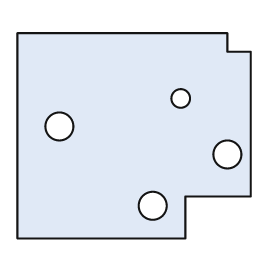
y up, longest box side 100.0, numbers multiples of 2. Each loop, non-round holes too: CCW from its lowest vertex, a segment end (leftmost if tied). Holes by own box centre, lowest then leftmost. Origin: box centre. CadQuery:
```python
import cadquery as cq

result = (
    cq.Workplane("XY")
    .moveTo(-50.0, -44.0)
    .lineTo(22.0, -44.0)
    .lineTo(22.0, -26.0)
    .lineTo(50.0, -26.0)
    .lineTo(50.0, 36.0)
    .lineTo(40.0, 36.0)
    .lineTo(40.0, 44.0)
    .lineTo(-50.0, 44.0)
    .close()
    .moveTo(8.0, -30.0)
    .circle(6.0)
    .moveTo(40.0, -8.0)
    .circle(6.0)
    .moveTo(-32.0, 4.0)
    .circle(6.0)
    .moveTo(20.0, 16.0)
    .circle(4.0)
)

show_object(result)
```